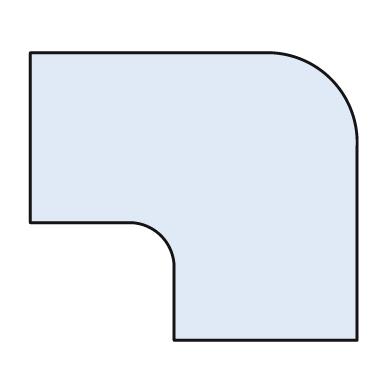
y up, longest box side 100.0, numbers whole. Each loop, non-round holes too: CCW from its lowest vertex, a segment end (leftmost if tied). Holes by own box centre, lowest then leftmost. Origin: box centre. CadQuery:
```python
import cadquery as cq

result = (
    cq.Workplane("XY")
    .moveTo(-6.0, -44.0)
    .lineTo(50.0, -44.0)
    .lineTo(50.0, 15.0)
    .threePointArc((42.0, 36.0), (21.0, 44.0))
    .lineTo(-50.0, 44.0)
    .lineTo(-50.0, -8.0)
    .lineTo(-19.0, -8.0)
    .threePointArc((-10.0, -12.0), (-6.0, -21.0))
    .close()
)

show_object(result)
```